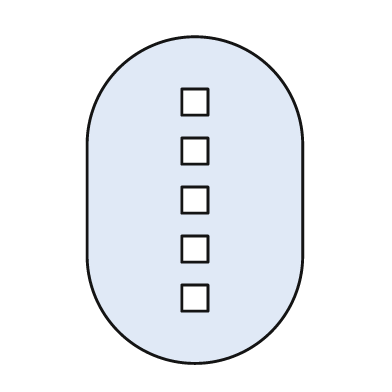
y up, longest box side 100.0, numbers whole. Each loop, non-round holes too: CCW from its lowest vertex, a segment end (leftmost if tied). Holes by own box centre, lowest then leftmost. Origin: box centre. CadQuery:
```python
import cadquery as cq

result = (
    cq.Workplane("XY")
    .moveTo(-33.0, -17.0)
    .threePointArc((0.0, -50.0), (33.0, -17.0))
    .lineTo(33.0, 17.0)
    .threePointArc((0.0, 50.0), (-33.0, 17.0))
    .close()
    .moveTo(-4.0, -34.0)
    .lineTo(4.0, -34.0)
    .lineTo(4.0, -26.0)
    .lineTo(-4.0, -26.0)
    .close()
    .moveTo(-4.0, -19.0)
    .lineTo(4.0, -19.0)
    .lineTo(4.0, -11.0)
    .lineTo(-4.0, -11.0)
    .close()
    .moveTo(-4.0, -4.0)
    .lineTo(4.0, -4.0)
    .lineTo(4.0, 4.0)
    .lineTo(-4.0, 4.0)
    .close()
    .moveTo(-4.0, 11.0)
    .lineTo(4.0, 11.0)
    .lineTo(4.0, 19.0)
    .lineTo(-4.0, 19.0)
    .close()
    .moveTo(-4.0, 26.0)
    .lineTo(4.0, 26.0)
    .lineTo(4.0, 34.0)
    .lineTo(-4.0, 34.0)
    .close()
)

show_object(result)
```